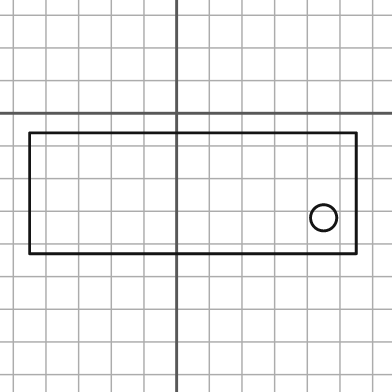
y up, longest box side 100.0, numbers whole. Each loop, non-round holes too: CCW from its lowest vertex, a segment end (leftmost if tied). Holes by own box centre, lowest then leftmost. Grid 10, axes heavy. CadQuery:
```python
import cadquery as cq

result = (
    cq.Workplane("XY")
    .moveTo(-45.0, -43.0)
    .lineTo(55.0, -43.0)
    .lineTo(55.0, -6.0)
    .lineTo(-45.0, -6.0)
    .close()
    .moveTo(45.0, -32.0)
    .circle(4.0)
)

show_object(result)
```